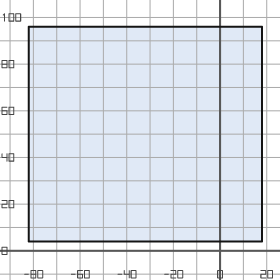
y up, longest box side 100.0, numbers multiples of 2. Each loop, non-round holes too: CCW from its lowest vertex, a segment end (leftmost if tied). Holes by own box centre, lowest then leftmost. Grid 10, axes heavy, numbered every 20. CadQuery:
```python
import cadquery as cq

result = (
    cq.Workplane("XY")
    .moveTo(-82.0, 4.0)
    .lineTo(18.0, 4.0)
    .lineTo(18.0, 96.0)
    .lineTo(-82.0, 96.0)
    .close()
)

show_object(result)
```